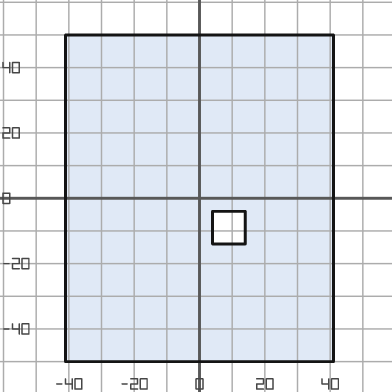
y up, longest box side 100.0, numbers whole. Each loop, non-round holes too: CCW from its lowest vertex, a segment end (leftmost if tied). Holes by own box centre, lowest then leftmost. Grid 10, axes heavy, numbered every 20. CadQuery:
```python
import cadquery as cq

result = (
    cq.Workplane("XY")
    .moveTo(-41.0, -50.0)
    .lineTo(41.0, -50.0)
    .lineTo(41.0, 50.0)
    .lineTo(-41.0, 50.0)
    .close()
    .moveTo(4.0, -14.0)
    .lineTo(14.0, -14.0)
    .lineTo(14.0, -4.0)
    .lineTo(4.0, -4.0)
    .close()
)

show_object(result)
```